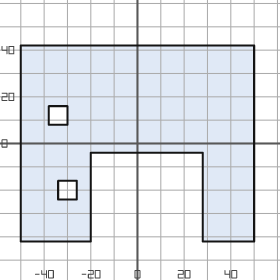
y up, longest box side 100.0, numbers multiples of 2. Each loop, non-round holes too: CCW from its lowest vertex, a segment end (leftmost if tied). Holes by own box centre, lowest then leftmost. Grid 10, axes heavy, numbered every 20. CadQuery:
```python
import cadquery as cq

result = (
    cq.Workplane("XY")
    .moveTo(-50.0, -42.0)
    .lineTo(-20.0, -42.0)
    .lineTo(-20.0, -4.0)
    .lineTo(28.0, -4.0)
    .lineTo(28.0, -42.0)
    .lineTo(50.0, -42.0)
    .lineTo(50.0, 42.0)
    .lineTo(-50.0, 42.0)
    .close()
    .moveTo(-34.0, -24.0)
    .lineTo(-26.0, -24.0)
    .lineTo(-26.0, -16.0)
    .lineTo(-34.0, -16.0)
    .close()
    .moveTo(-38.0, 8.0)
    .lineTo(-30.0, 8.0)
    .lineTo(-30.0, 16.0)
    .lineTo(-38.0, 16.0)
    .close()
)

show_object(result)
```